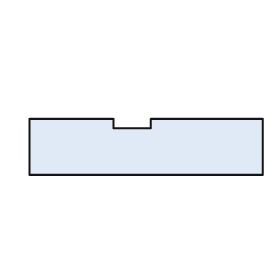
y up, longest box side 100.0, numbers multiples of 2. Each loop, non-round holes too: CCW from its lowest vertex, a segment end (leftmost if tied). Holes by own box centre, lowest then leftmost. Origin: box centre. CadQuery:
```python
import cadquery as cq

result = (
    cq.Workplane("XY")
    .moveTo(-50.0, -12.0)
    .lineTo(50.0, -12.0)
    .lineTo(50.0, 12.0)
    .lineTo(2.0, 12.0)
    .lineTo(2.0, 8.0)
    .lineTo(-14.0, 8.0)
    .lineTo(-14.0, 12.0)
    .lineTo(-50.0, 12.0)
    .close()
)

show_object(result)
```